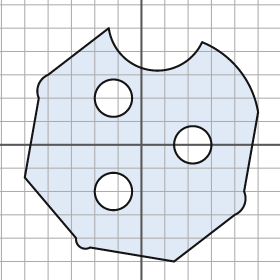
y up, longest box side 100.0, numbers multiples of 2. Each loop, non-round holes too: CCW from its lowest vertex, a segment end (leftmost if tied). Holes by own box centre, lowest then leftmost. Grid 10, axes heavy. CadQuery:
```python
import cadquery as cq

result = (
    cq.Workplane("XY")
    .moveTo(14.0, -50.0)
    .lineTo(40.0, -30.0)
    .threePointArc((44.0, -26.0), (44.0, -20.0))
    .lineTo(50.0, 14.0)
    .threePointArc((42.0, 32.0), (26.0, 44.0))
    .threePointArc((4.0, 32.0), (-14.0, 50.0))
    .lineTo(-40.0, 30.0)
    .threePointArc((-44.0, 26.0), (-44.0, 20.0))
    .lineTo(-50.0, -14.0)
    .lineTo(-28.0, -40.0)
    .threePointArc((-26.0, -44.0), (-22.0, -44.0))
    .close()
    .moveTo(-12.0, -20.0)
    .circle(8.0)
    .moveTo(22.0, 0.0)
    .circle(8.0)
    .moveTo(-12.0, 20.0)
    .circle(8.0)
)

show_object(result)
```